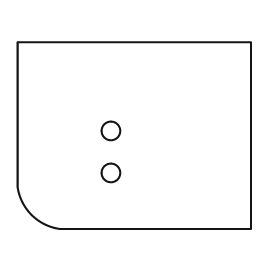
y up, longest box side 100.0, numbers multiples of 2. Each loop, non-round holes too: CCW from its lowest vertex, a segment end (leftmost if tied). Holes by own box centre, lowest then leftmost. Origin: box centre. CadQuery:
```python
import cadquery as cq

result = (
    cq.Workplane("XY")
    .moveTo(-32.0, -40.0)
    .lineTo(50.0, -40.0)
    .lineTo(50.0, 40.0)
    .lineTo(-50.0, 40.0)
    .lineTo(-50.0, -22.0)
    .threePointArc((-44.0, -34.0), (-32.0, -40.0))
    .close()
    .moveTo(-10.0, -16.0)
    .circle(4.0)
    .moveTo(-10.0, 2.0)
    .circle(4.0)
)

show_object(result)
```